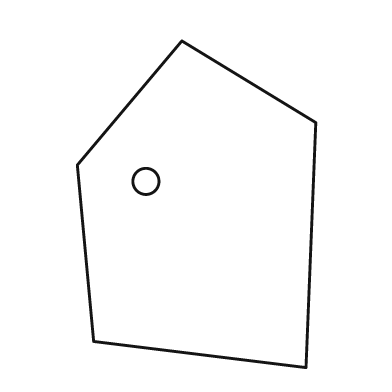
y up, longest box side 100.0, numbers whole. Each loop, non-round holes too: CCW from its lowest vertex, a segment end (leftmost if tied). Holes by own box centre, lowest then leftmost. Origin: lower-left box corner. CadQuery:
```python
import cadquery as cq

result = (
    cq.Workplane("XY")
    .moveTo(70.0, 0.0)
    .lineTo(73.0, 75.0)
    .lineTo(32.0, 100.0)
    .lineTo(0.0, 62.0)
    .lineTo(5.0, 8.0)
    .close()
    .moveTo(21.0, 57.0)
    .circle(4.0)
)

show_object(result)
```